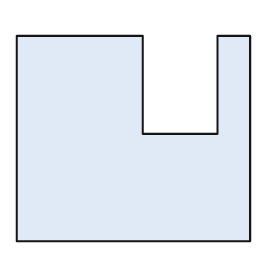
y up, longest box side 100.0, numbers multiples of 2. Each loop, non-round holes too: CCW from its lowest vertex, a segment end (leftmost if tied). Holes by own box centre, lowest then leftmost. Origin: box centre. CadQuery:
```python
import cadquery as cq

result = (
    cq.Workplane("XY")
    .moveTo(-50.0, -44.0)
    .lineTo(50.0, -44.0)
    .lineTo(50.0, 44.0)
    .lineTo(36.0, 44.0)
    .lineTo(36.0, 2.0)
    .lineTo(4.0, 2.0)
    .lineTo(4.0, 44.0)
    .lineTo(-50.0, 44.0)
    .close()
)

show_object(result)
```